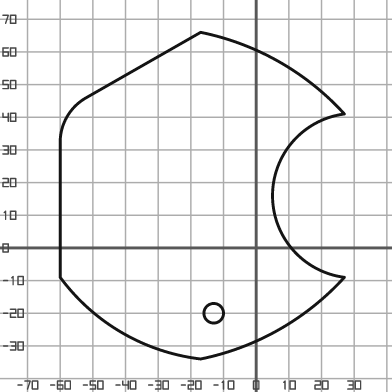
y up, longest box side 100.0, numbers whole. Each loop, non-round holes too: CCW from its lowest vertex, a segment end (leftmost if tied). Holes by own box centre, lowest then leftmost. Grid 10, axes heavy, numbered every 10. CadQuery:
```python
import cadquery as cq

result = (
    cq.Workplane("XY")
    .moveTo(-17.0, -34.0)
    .threePointArc((7.0, -25.0), (27.0, -9.0))
    .threePointArc((5.0, 16.0), (27.0, 41.0))
    .threePointArc((7.0, 57.0), (-17.0, 66.0))
    .lineTo(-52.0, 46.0)
    .threePointArc((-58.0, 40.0), (-60.0, 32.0))
    .lineTo(-60.0, -9.0)
    .threePointArc((-41.0, -26.0), (-17.0, -34.0))
    .close()
    .moveTo(-13.0, -20.0)
    .circle(3.0)
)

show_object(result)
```